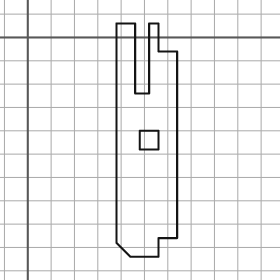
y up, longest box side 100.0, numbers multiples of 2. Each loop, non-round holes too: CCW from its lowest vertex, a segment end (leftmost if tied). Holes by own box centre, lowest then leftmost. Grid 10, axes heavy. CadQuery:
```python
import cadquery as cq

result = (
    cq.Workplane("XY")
    .moveTo(44.0, -94.0)
    .lineTo(56.0, -94.0)
    .lineTo(56.0, -86.0)
    .lineTo(64.0, -86.0)
    .lineTo(64.0, -6.0)
    .lineTo(56.0, -6.0)
    .lineTo(56.0, 6.0)
    .lineTo(52.0, 6.0)
    .lineTo(52.0, -24.0)
    .lineTo(46.0, -24.0)
    .lineTo(46.0, 6.0)
    .lineTo(38.0, 6.0)
    .lineTo(38.0, -88.0)
    .close()
    .moveTo(48.0, -48.0)
    .lineTo(56.0, -48.0)
    .lineTo(56.0, -40.0)
    .lineTo(48.0, -40.0)
    .close()
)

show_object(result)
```